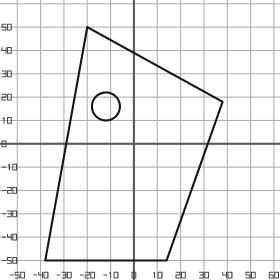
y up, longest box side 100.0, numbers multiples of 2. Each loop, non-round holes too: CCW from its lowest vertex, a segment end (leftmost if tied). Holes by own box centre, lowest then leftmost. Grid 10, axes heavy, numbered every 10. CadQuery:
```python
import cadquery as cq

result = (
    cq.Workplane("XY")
    .moveTo(-38.0, -50.0)
    .lineTo(14.0, -50.0)
    .lineTo(38.0, 18.0)
    .lineTo(-20.0, 50.0)
    .close()
    .moveTo(-12.0, 16.0)
    .circle(6.0)
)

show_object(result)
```